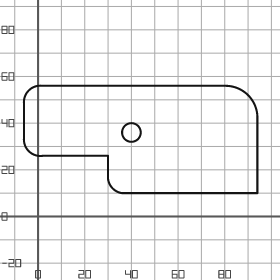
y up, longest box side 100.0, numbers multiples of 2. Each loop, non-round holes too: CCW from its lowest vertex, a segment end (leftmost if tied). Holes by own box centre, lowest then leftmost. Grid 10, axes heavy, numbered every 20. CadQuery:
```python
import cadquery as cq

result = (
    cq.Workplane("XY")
    .moveTo(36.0, 10.0)
    .lineTo(94.0, 10.0)
    .lineTo(94.0, 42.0)
    .threePointArc((90.0, 52.0), (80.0, 56.0))
    .lineTo(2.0, 56.0)
    .threePointArc((-4.0, 54.0), (-6.0, 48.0))
    .lineTo(-6.0, 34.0)
    .threePointArc((-4.0, 28.0), (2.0, 26.0))
    .lineTo(30.0, 26.0)
    .lineTo(30.0, 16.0)
    .threePointArc((32.0, 12.0), (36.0, 10.0))
    .close()
    .moveTo(40.0, 36.0)
    .circle(4.0)
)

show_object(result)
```